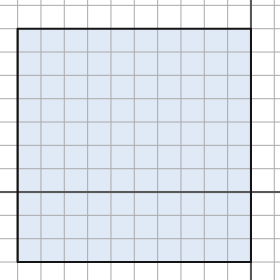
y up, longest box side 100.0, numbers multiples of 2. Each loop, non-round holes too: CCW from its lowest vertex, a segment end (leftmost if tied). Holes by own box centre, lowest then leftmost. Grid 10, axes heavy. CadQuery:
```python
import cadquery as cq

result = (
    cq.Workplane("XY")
    .moveTo(-100.0, -30.0)
    .lineTo(0.0, -30.0)
    .lineTo(0.0, 70.0)
    .lineTo(-100.0, 70.0)
    .close()
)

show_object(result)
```